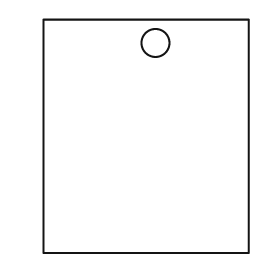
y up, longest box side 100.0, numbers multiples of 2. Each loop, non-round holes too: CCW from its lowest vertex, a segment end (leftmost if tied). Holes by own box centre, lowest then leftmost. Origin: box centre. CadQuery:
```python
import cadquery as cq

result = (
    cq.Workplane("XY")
    .moveTo(-44.0, -50.0)
    .lineTo(44.0, -50.0)
    .lineTo(44.0, 50.0)
    .lineTo(-44.0, 50.0)
    .close()
    .moveTo(4.0, 40.0)
    .circle(6.0)
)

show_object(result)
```